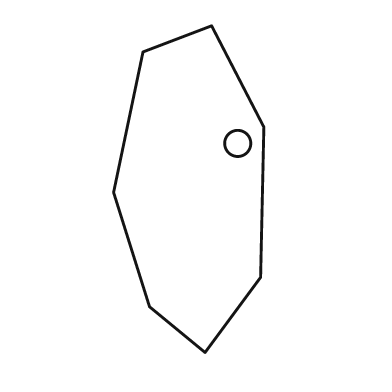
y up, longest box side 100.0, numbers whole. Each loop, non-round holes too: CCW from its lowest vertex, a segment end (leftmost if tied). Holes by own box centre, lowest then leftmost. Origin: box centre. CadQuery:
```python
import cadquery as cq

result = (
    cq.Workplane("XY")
    .moveTo(5.0, -50.0)
    .lineTo(22.0, -27.0)
    .lineTo(23.0, 19.0)
    .lineTo(7.0, 50.0)
    .lineTo(-14.0, 42.0)
    .lineTo(-23.0, -1.0)
    .lineTo(-12.0, -36.0)
    .close()
    .moveTo(15.0, 14.0)
    .circle(4.0)
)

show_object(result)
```